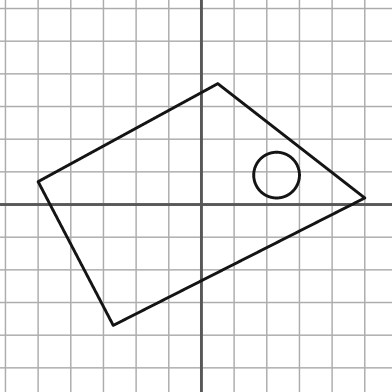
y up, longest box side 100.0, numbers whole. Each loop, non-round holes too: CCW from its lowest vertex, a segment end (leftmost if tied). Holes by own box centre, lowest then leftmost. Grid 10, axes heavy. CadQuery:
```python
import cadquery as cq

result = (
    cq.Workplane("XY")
    .moveTo(-27.0, -37.0)
    .lineTo(50.0, 2.0)
    .lineTo(5.0, 37.0)
    .lineTo(-50.0, 7.0)
    .close()
    .moveTo(23.0, 9.0)
    .circle(7.0)
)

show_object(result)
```